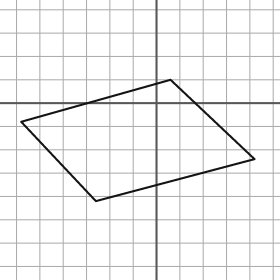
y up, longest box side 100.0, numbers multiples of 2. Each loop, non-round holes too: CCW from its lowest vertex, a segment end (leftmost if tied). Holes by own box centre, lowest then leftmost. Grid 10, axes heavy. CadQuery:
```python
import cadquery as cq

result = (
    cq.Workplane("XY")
    .moveTo(-26.0, -42.0)
    .lineTo(42.0, -24.0)
    .lineTo(6.0, 10.0)
    .lineTo(-58.0, -8.0)
    .close()
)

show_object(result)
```